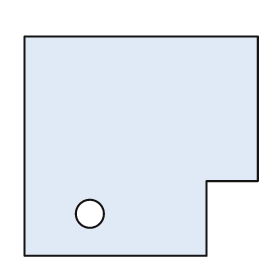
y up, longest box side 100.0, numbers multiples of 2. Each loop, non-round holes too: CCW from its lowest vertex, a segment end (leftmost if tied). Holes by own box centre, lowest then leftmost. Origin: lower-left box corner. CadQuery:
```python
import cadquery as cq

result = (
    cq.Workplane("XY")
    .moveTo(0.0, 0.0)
    .lineTo(78.0, 0.0)
    .lineTo(78.0, 32.0)
    .lineTo(100.0, 32.0)
    .lineTo(100.0, 94.0)
    .lineTo(0.0, 94.0)
    .close()
    .moveTo(28.0, 18.0)
    .circle(6.0)
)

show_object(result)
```